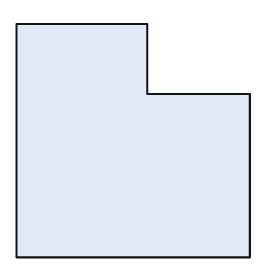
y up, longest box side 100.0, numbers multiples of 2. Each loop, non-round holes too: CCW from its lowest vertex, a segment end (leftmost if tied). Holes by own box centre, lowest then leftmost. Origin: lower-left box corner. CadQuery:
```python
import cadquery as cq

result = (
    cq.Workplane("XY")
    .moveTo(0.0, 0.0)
    .lineTo(100.0, 0.0)
    .lineTo(100.0, 70.0)
    .lineTo(56.0, 70.0)
    .lineTo(56.0, 100.0)
    .lineTo(0.0, 100.0)
    .close()
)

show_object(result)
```